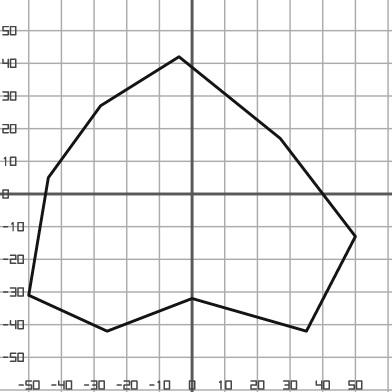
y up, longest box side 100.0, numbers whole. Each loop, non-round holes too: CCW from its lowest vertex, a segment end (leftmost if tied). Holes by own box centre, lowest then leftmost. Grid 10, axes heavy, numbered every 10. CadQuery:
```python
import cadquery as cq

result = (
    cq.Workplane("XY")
    .moveTo(-26.0, -42.0)
    .lineTo(0.0, -32.0)
    .lineTo(35.0, -42.0)
    .lineTo(50.0, -13.0)
    .lineTo(27.0, 17.0)
    .lineTo(-4.0, 42.0)
    .lineTo(-28.0, 27.0)
    .lineTo(-44.0, 5.0)
    .lineTo(-50.0, -31.0)
    .close()
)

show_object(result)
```